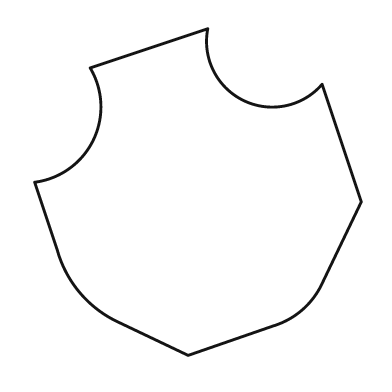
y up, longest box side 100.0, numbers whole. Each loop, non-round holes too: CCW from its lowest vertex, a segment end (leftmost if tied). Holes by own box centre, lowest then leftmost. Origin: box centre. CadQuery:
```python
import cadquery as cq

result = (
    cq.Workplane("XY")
    .moveTo(-3.0, -50.0)
    .lineTo(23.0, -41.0)
    .threePointArc((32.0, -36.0), (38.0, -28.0))
    .lineTo(50.0, -3.0)
    .lineTo(38.0, 33.0)
    .threePointArc((14.0, 28.0), (3.0, 50.0))
    .lineTo(-33.0, 38.0)
    .threePointArc((-32.0, 16.0), (-50.0, 3.0))
    .lineTo(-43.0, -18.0)
    .threePointArc((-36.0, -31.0), (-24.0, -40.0))
    .close()
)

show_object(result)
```